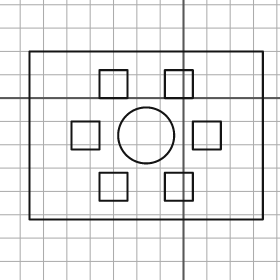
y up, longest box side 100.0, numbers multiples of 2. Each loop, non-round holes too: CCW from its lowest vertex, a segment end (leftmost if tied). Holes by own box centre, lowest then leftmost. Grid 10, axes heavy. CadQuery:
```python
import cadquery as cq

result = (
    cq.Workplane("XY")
    .moveTo(-66.0, -52.0)
    .lineTo(34.0, -52.0)
    .lineTo(34.0, 20.0)
    .lineTo(-66.0, 20.0)
    .close()
    .moveTo(-36.0, -44.0)
    .lineTo(-24.0, -44.0)
    .lineTo(-24.0, -32.0)
    .lineTo(-36.0, -32.0)
    .close()
    .moveTo(-8.0, -44.0)
    .lineTo(4.0, -44.0)
    .lineTo(4.0, -32.0)
    .lineTo(-8.0, -32.0)
    .close()
    .moveTo(-48.0, -22.0)
    .lineTo(-36.0, -22.0)
    .lineTo(-36.0, -10.0)
    .lineTo(-48.0, -10.0)
    .close()
    .moveTo(-16.0, -16.0)
    .circle(12.0)
    .moveTo(4.0, -22.0)
    .lineTo(16.0, -22.0)
    .lineTo(16.0, -10.0)
    .lineTo(4.0, -10.0)
    .close()
    .moveTo(-36.0, 0.0)
    .lineTo(-24.0, 0.0)
    .lineTo(-24.0, 12.0)
    .lineTo(-36.0, 12.0)
    .close()
    .moveTo(-8.0, 0.0)
    .lineTo(4.0, 0.0)
    .lineTo(4.0, 12.0)
    .lineTo(-8.0, 12.0)
    .close()
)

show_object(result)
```